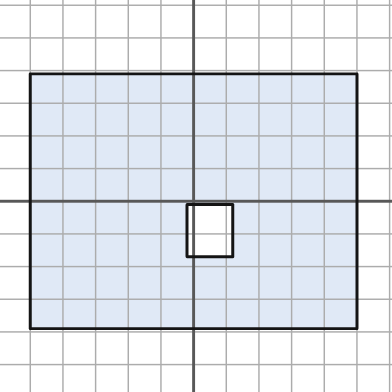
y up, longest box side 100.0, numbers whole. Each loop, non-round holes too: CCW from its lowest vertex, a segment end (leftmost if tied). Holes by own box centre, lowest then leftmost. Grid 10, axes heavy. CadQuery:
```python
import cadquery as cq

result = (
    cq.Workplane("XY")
    .moveTo(-50.0, -39.0)
    .lineTo(50.0, -39.0)
    .lineTo(50.0, 39.0)
    .lineTo(-50.0, 39.0)
    .close()
    .moveTo(-2.0, -17.0)
    .lineTo(12.0, -17.0)
    .lineTo(12.0, -1.0)
    .lineTo(-2.0, -1.0)
    .close()
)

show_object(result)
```